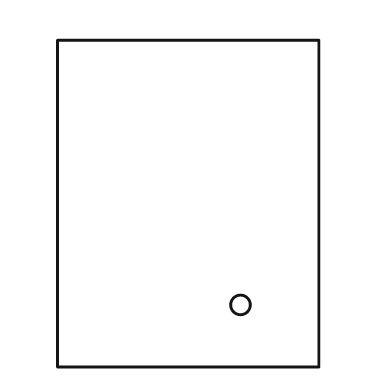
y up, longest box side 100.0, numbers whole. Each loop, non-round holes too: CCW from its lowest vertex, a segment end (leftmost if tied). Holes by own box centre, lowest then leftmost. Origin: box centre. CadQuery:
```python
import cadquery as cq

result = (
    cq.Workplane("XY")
    .moveTo(-40.0, -50.0)
    .lineTo(40.0, -50.0)
    .lineTo(40.0, 50.0)
    .lineTo(-40.0, 50.0)
    .close()
    .moveTo(16.0, -31.0)
    .circle(3.0)
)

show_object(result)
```